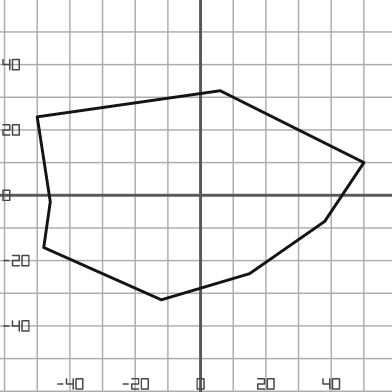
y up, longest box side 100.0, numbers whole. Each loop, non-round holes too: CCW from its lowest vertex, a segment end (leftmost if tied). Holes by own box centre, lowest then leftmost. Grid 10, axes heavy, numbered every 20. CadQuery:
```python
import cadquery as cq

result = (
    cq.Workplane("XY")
    .moveTo(-12.0, -32.0)
    .lineTo(15.0, -24.0)
    .lineTo(38.0, -8.0)
    .lineTo(50.0, 10.0)
    .lineTo(6.0, 32.0)
    .lineTo(-50.0, 24.0)
    .lineTo(-46.0, -2.0)
    .lineTo(-48.0, -16.0)
    .close()
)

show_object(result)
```